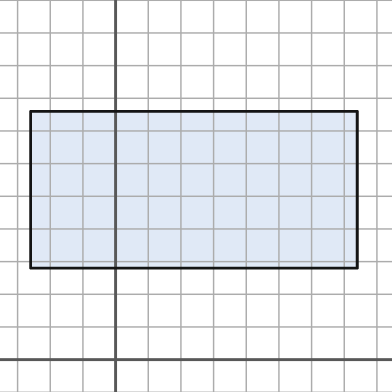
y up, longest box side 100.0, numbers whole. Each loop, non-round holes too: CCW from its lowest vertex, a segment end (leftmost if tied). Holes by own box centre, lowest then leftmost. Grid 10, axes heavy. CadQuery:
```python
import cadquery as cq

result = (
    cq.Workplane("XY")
    .moveTo(-26.0, 28.0)
    .lineTo(74.0, 28.0)
    .lineTo(74.0, 76.0)
    .lineTo(-26.0, 76.0)
    .close()
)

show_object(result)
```